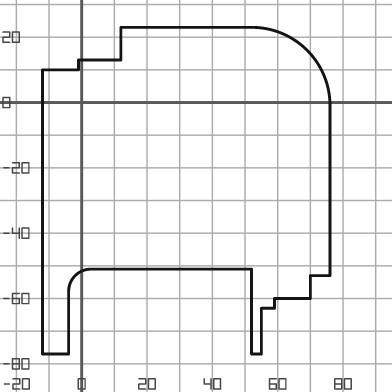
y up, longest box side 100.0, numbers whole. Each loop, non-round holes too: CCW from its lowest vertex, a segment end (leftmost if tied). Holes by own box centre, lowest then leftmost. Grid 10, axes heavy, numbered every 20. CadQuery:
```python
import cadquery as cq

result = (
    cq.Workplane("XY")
    .moveTo(-12.0, -77.0)
    .lineTo(-4.0, -77.0)
    .lineTo(-4.0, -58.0)
    .threePointArc((-2.0, -53.0), (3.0, -51.0))
    .lineTo(52.0, -51.0)
    .lineTo(52.0, -77.0)
    .lineTo(55.0, -77.0)
    .lineTo(55.0, -63.0)
    .lineTo(59.0, -63.0)
    .lineTo(59.0, -60.0)
    .lineTo(70.0, -60.0)
    .lineTo(70.0, -53.0)
    .lineTo(76.0, -53.0)
    .lineTo(76.0, 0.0)
    .threePointArc((69.0, 16.0), (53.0, 23.0))
    .lineTo(12.0, 23.0)
    .lineTo(12.0, 13.0)
    .lineTo(-1.0, 13.0)
    .lineTo(-1.0, 10.0)
    .lineTo(-12.0, 10.0)
    .close()
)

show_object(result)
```